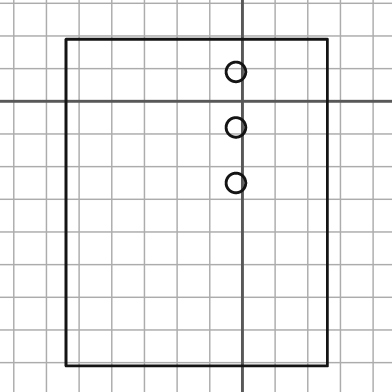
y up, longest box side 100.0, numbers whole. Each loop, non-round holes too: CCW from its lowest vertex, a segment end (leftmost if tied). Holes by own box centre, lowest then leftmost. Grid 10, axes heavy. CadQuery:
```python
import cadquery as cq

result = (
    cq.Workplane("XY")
    .moveTo(-54.0, -81.0)
    .lineTo(26.0, -81.0)
    .lineTo(26.0, 19.0)
    .lineTo(-54.0, 19.0)
    .close()
    .moveTo(-2.0, -25.0)
    .circle(3.0)
    .moveTo(-2.0, -8.0)
    .circle(3.0)
    .moveTo(-2.0, 9.0)
    .circle(3.0)
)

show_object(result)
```